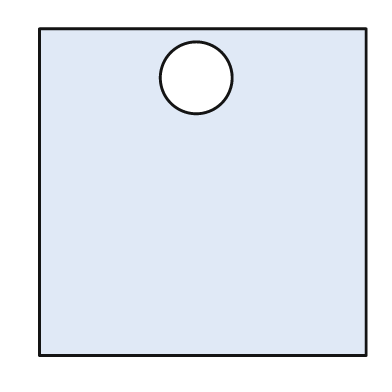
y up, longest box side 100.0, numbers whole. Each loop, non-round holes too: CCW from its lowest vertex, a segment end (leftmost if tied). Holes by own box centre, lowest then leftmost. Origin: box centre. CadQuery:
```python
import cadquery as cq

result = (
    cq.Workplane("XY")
    .moveTo(-50.0, -50.0)
    .lineTo(50.0, -50.0)
    .lineTo(50.0, 50.0)
    .lineTo(-50.0, 50.0)
    .close()
    .moveTo(-2.0, 35.0)
    .circle(11.0)
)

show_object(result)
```